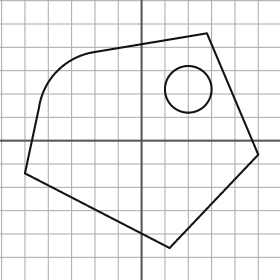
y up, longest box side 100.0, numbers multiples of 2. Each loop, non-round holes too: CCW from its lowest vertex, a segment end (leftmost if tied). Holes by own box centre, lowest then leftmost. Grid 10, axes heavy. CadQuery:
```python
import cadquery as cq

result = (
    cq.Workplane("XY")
    .moveTo(12.0, -46.0)
    .lineTo(50.0, -6.0)
    .lineTo(28.0, 46.0)
    .lineTo(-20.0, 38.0)
    .threePointArc((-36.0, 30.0), (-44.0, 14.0))
    .lineTo(-50.0, -14.0)
    .close()
    .moveTo(20.0, 22.0)
    .circle(10.0)
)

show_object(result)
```